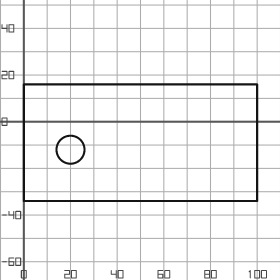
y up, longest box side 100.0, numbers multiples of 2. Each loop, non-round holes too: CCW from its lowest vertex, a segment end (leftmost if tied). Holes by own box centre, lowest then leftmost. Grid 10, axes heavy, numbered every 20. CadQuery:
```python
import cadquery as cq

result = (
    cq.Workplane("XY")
    .moveTo(0.0, -34.0)
    .lineTo(100.0, -34.0)
    .lineTo(100.0, 16.0)
    .lineTo(0.0, 16.0)
    .close()
    .moveTo(20.0, -12.0)
    .circle(6.0)
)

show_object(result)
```